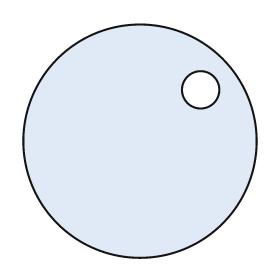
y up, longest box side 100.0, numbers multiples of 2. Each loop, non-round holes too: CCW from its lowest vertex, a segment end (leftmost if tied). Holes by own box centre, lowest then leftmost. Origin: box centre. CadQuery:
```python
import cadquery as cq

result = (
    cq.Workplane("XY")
    .moveTo(0.0, 0.0)
    .circle(50.0)
    .moveTo(26.0, 22.0)
    .circle(8.0)
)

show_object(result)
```